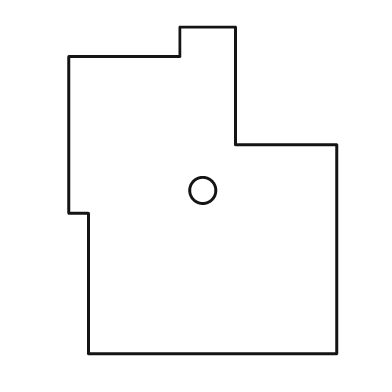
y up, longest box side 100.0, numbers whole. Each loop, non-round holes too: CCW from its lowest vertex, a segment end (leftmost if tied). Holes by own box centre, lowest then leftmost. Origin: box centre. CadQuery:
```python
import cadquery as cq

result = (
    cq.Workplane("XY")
    .moveTo(-35.0, -50.0)
    .lineTo(41.0, -50.0)
    .lineTo(41.0, 14.0)
    .lineTo(10.0, 14.0)
    .lineTo(10.0, 50.0)
    .lineTo(-7.0, 50.0)
    .lineTo(-7.0, 41.0)
    .lineTo(-41.0, 41.0)
    .lineTo(-41.0, -7.0)
    .lineTo(-35.0, -7.0)
    .close()
    .moveTo(0.0, 0.0)
    .circle(4.0)
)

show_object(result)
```